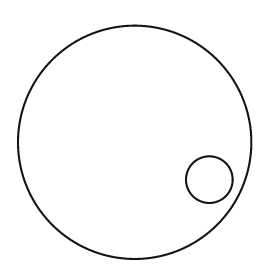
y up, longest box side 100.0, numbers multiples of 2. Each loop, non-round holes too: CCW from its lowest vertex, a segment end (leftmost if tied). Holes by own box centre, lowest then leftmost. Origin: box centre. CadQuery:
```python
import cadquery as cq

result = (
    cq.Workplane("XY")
    .moveTo(0.0, 0.0)
    .circle(50.0)
    .moveTo(32.0, -16.0)
    .circle(10.0)
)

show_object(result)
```